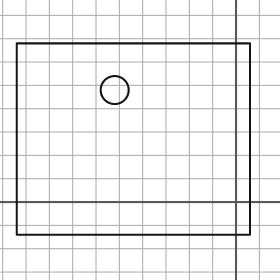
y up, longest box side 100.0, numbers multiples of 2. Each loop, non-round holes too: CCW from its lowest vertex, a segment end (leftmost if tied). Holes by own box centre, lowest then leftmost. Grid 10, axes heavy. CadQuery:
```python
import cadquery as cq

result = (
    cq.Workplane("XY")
    .moveTo(-94.0, -14.0)
    .lineTo(6.0, -14.0)
    .lineTo(6.0, 68.0)
    .lineTo(-94.0, 68.0)
    .close()
    .moveTo(-52.0, 48.0)
    .circle(6.0)
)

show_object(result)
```